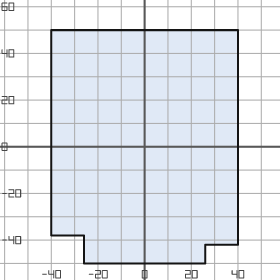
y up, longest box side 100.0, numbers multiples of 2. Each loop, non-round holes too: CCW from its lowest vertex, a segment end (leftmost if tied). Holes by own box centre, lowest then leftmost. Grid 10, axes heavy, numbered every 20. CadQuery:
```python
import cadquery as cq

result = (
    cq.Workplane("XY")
    .moveTo(-26.0, -50.0)
    .lineTo(26.0, -50.0)
    .lineTo(26.0, -42.0)
    .lineTo(40.0, -42.0)
    .lineTo(40.0, 50.0)
    .lineTo(-40.0, 50.0)
    .lineTo(-40.0, -38.0)
    .lineTo(-26.0, -38.0)
    .close()
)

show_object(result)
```